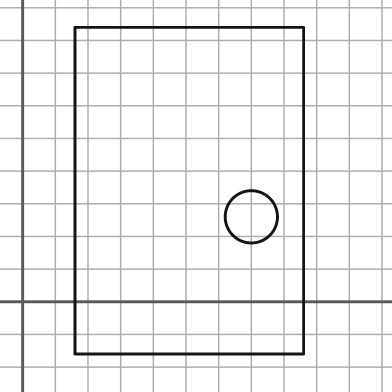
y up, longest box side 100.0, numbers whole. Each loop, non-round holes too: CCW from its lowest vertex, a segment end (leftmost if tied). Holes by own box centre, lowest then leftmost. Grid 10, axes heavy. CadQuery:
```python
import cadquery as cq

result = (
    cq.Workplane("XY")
    .moveTo(16.0, -16.0)
    .lineTo(86.0, -16.0)
    .lineTo(86.0, 84.0)
    .lineTo(16.0, 84.0)
    .close()
    .moveTo(70.0, 26.0)
    .circle(8.0)
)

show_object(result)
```